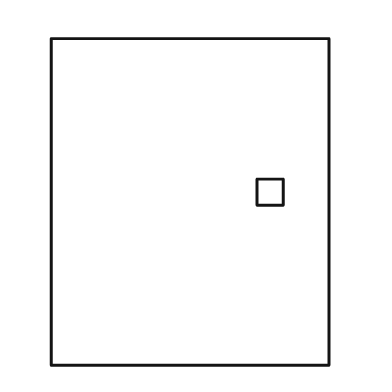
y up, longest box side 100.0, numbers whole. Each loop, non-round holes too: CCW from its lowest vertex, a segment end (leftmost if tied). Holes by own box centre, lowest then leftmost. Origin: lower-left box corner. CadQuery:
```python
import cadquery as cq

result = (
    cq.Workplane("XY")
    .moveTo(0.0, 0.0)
    .lineTo(85.0, 0.0)
    .lineTo(85.0, 100.0)
    .lineTo(0.0, 100.0)
    .close()
    .moveTo(63.0, 49.0)
    .lineTo(71.0, 49.0)
    .lineTo(71.0, 57.0)
    .lineTo(63.0, 57.0)
    .close()
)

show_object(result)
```